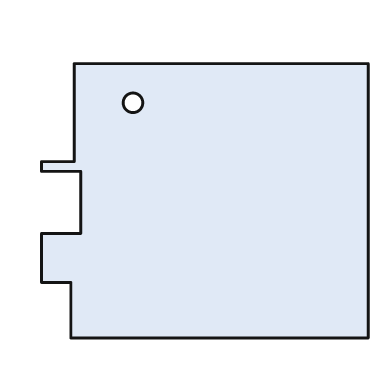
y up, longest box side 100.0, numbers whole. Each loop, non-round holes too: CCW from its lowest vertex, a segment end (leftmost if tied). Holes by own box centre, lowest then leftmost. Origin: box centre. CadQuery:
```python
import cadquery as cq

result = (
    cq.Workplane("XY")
    .moveTo(-41.0, -42.0)
    .lineTo(50.0, -42.0)
    .lineTo(50.0, 42.0)
    .lineTo(-40.0, 42.0)
    .lineTo(-40.0, 12.0)
    .lineTo(-50.0, 12.0)
    .lineTo(-50.0, 9.0)
    .lineTo(-38.0, 9.0)
    .lineTo(-38.0, -10.0)
    .lineTo(-50.0, -10.0)
    .lineTo(-50.0, -25.0)
    .lineTo(-41.0, -25.0)
    .close()
    .moveTo(-22.0, 30.0)
    .circle(3.0)
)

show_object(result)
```